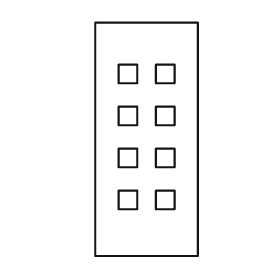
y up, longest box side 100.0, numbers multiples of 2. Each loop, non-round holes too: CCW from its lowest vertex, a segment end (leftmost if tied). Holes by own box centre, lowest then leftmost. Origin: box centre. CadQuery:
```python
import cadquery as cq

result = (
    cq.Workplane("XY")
    .moveTo(-22.0, -50.0)
    .lineTo(22.0, -50.0)
    .lineTo(22.0, 50.0)
    .lineTo(-22.0, 50.0)
    .close()
    .moveTo(-12.0, -30.0)
    .lineTo(-4.0, -30.0)
    .lineTo(-4.0, -22.0)
    .lineTo(-12.0, -22.0)
    .close()
    .moveTo(4.0, -30.0)
    .lineTo(12.0, -30.0)
    .lineTo(12.0, -22.0)
    .lineTo(4.0, -22.0)
    .close()
    .moveTo(-12.0, -12.0)
    .lineTo(-4.0, -12.0)
    .lineTo(-4.0, -4.0)
    .lineTo(-12.0, -4.0)
    .close()
    .moveTo(4.0, -12.0)
    .lineTo(12.0, -12.0)
    .lineTo(12.0, -4.0)
    .lineTo(4.0, -4.0)
    .close()
    .moveTo(-12.0, 6.0)
    .lineTo(-4.0, 6.0)
    .lineTo(-4.0, 14.0)
    .lineTo(-12.0, 14.0)
    .close()
    .moveTo(4.0, 6.0)
    .lineTo(12.0, 6.0)
    .lineTo(12.0, 14.0)
    .lineTo(4.0, 14.0)
    .close()
    .moveTo(-12.0, 24.0)
    .lineTo(-4.0, 24.0)
    .lineTo(-4.0, 32.0)
    .lineTo(-12.0, 32.0)
    .close()
    .moveTo(4.0, 24.0)
    .lineTo(12.0, 24.0)
    .lineTo(12.0, 32.0)
    .lineTo(4.0, 32.0)
    .close()
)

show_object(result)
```